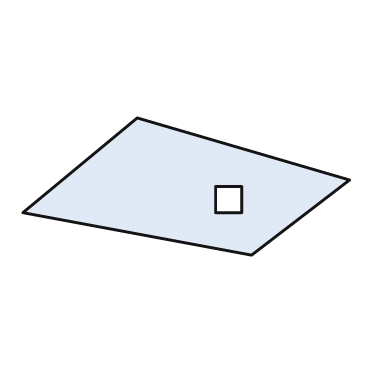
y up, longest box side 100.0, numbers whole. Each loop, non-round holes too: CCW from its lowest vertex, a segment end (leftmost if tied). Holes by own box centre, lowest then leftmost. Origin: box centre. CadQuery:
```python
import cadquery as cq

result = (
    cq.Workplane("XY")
    .moveTo(20.0, -21.0)
    .lineTo(50.0, 2.0)
    .lineTo(-15.0, 21.0)
    .lineTo(-50.0, -8.0)
    .close()
    .moveTo(9.0, -8.0)
    .lineTo(17.0, -8.0)
    .lineTo(17.0, 0.0)
    .lineTo(9.0, 0.0)
    .close()
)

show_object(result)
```